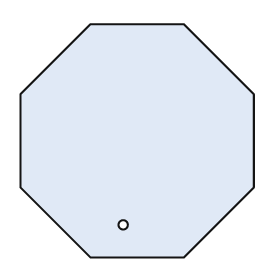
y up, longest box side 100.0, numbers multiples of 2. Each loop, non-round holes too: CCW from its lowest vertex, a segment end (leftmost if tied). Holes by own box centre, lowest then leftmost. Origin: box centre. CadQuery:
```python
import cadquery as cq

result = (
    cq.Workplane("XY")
    .moveTo(-20.0, -50.0)
    .lineTo(20.0, -50.0)
    .lineTo(50.0, -20.0)
    .lineTo(50.0, 20.0)
    .lineTo(20.0, 50.0)
    .lineTo(-20.0, 50.0)
    .lineTo(-50.0, 20.0)
    .lineTo(-50.0, -20.0)
    .close()
    .moveTo(-6.0, -36.0)
    .circle(2.0)
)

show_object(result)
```